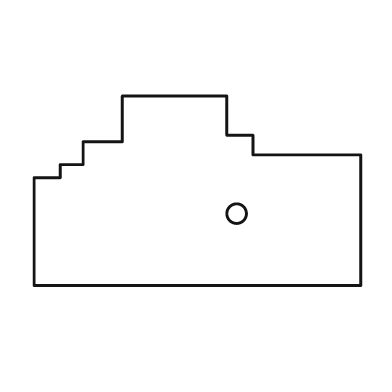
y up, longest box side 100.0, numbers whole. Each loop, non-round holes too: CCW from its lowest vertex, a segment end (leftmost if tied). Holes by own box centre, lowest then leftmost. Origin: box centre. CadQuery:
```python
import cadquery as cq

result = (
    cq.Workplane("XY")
    .moveTo(-50.0, -29.0)
    .lineTo(50.0, -29.0)
    .lineTo(50.0, 11.0)
    .lineTo(17.0, 11.0)
    .lineTo(17.0, 17.0)
    .lineTo(9.0, 17.0)
    .lineTo(9.0, 29.0)
    .lineTo(-23.0, 29.0)
    .lineTo(-23.0, 15.0)
    .lineTo(-35.0, 15.0)
    .lineTo(-35.0, 8.0)
    .lineTo(-42.0, 8.0)
    .lineTo(-42.0, 4.0)
    .lineTo(-50.0, 4.0)
    .close()
    .moveTo(12.0, -7.0)
    .circle(3.0)
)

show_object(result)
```